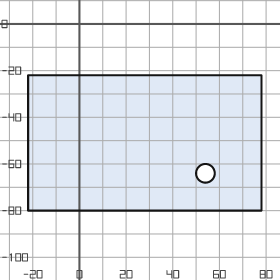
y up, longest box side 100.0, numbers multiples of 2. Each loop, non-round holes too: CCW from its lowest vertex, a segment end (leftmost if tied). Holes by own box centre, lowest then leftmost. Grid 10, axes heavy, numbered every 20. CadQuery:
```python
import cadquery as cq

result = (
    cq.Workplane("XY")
    .moveTo(-22.0, -80.0)
    .lineTo(78.0, -80.0)
    .lineTo(78.0, -22.0)
    .lineTo(-22.0, -22.0)
    .close()
    .moveTo(54.0, -64.0)
    .circle(4.0)
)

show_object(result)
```